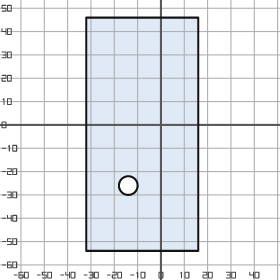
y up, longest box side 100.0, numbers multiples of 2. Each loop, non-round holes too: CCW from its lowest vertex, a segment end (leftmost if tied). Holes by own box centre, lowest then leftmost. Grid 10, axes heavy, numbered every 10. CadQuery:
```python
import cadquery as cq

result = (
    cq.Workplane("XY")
    .moveTo(-32.0, -54.0)
    .lineTo(16.0, -54.0)
    .lineTo(16.0, 46.0)
    .lineTo(-32.0, 46.0)
    .close()
    .moveTo(-14.0, -26.0)
    .circle(4.0)
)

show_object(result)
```